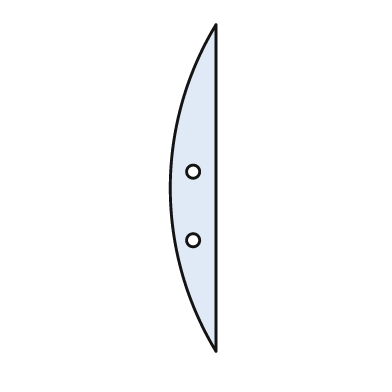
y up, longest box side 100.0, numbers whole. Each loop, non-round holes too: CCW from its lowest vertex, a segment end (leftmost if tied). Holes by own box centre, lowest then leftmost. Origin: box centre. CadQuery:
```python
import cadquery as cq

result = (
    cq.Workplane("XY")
    .moveTo(7.0, -50.0)
    .lineTo(7.0, 50.0)
    .threePointArc((-7.0, 0.0), (7.0, -50.0))
    .close()
    .moveTo(0.0, -16.0)
    .circle(2.0)
    .moveTo(0.0, 5.0)
    .circle(2.0)
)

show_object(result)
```